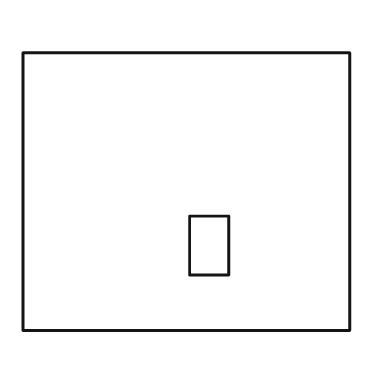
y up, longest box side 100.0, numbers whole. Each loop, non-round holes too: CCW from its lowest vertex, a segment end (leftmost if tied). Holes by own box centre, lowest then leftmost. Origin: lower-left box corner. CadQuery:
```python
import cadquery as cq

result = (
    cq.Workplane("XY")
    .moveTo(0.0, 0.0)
    .lineTo(100.0, 0.0)
    .lineTo(100.0, 85.0)
    .lineTo(0.0, 85.0)
    .close()
    .moveTo(51.0, 17.0)
    .lineTo(63.0, 17.0)
    .lineTo(63.0, 35.0)
    .lineTo(51.0, 35.0)
    .close()
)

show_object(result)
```